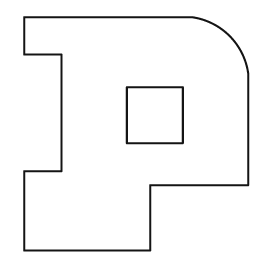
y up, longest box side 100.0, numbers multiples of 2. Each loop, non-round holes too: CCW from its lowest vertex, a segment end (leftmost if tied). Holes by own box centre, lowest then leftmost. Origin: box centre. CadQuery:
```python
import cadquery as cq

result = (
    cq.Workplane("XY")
    .moveTo(-48.0, -50.0)
    .lineTo(6.0, -50.0)
    .lineTo(6.0, -22.0)
    .lineTo(48.0, -22.0)
    .lineTo(48.0, 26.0)
    .threePointArc((40.0, 42.0), (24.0, 50.0))
    .lineTo(-48.0, 50.0)
    .lineTo(-48.0, 34.0)
    .lineTo(-32.0, 34.0)
    .lineTo(-32.0, -16.0)
    .lineTo(-48.0, -16.0)
    .close()
    .moveTo(-4.0, -4.0)
    .lineTo(20.0, -4.0)
    .lineTo(20.0, 20.0)
    .lineTo(-4.0, 20.0)
    .close()
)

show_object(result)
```